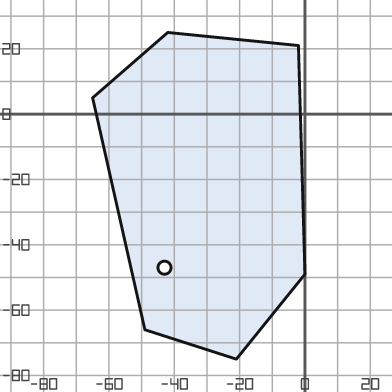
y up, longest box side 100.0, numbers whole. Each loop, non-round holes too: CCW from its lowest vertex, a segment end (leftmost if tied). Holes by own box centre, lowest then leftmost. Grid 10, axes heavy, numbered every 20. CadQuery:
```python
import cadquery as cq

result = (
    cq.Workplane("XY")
    .moveTo(-21.0, -75.0)
    .lineTo(0.0, -49.0)
    .lineTo(-2.0, 21.0)
    .lineTo(-42.0, 25.0)
    .lineTo(-65.0, 5.0)
    .lineTo(-49.0, -66.0)
    .close()
    .moveTo(-43.0, -47.0)
    .circle(2.0)
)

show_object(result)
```